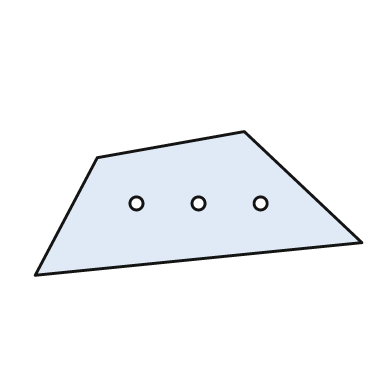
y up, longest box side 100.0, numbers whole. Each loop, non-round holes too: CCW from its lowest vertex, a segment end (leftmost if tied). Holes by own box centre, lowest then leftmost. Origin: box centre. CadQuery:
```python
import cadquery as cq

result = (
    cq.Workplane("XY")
    .moveTo(-50.0, -22.0)
    .lineTo(50.0, -12.0)
    .lineTo(14.0, 22.0)
    .lineTo(-31.0, 14.0)
    .close()
    .moveTo(-19.0, 0.0)
    .circle(2.0)
    .moveTo(0.0, 0.0)
    .circle(2.0)
    .moveTo(19.0, 0.0)
    .circle(2.0)
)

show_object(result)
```